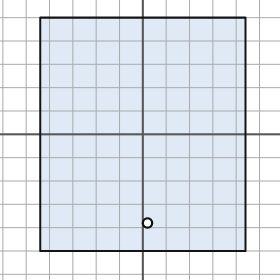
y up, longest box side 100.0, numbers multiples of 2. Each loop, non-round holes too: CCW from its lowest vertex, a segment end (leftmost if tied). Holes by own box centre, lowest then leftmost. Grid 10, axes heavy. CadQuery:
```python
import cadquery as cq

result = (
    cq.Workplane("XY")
    .moveTo(-44.0, -50.0)
    .lineTo(44.0, -50.0)
    .lineTo(44.0, 50.0)
    .lineTo(-44.0, 50.0)
    .close()
    .moveTo(2.0, -38.0)
    .circle(2.0)
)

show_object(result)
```